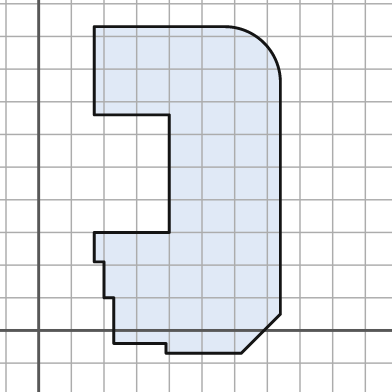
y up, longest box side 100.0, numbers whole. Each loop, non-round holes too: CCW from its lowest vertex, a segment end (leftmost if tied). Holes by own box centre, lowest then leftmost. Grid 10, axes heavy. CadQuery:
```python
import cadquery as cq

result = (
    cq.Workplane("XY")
    .moveTo(39.0, -7.0)
    .lineTo(62.0, -7.0)
    .lineTo(74.0, 5.0)
    .lineTo(74.0, 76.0)
    .threePointArc((69.0, 88.0), (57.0, 93.0))
    .lineTo(17.0, 93.0)
    .lineTo(17.0, 66.0)
    .lineTo(40.0, 66.0)
    .lineTo(40.0, 30.0)
    .lineTo(17.0, 30.0)
    .lineTo(17.0, 21.0)
    .lineTo(20.0, 21.0)
    .lineTo(20.0, 10.0)
    .lineTo(23.0, 10.0)
    .lineTo(23.0, -4.0)
    .lineTo(39.0, -4.0)
    .close()
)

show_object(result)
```